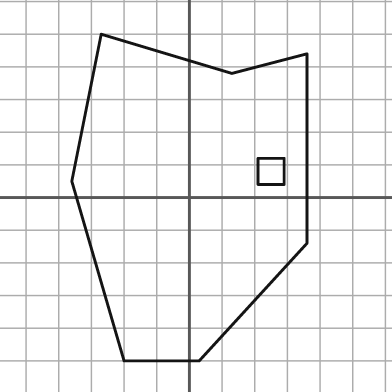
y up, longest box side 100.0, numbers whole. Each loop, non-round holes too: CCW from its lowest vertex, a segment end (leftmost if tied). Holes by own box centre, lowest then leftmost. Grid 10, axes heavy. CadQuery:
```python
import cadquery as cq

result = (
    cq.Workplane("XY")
    .moveTo(-20.0, -50.0)
    .lineTo(3.0, -50.0)
    .lineTo(36.0, -14.0)
    .lineTo(36.0, 44.0)
    .lineTo(13.0, 38.0)
    .lineTo(-27.0, 50.0)
    .lineTo(-36.0, 5.0)
    .close()
    .moveTo(21.0, 4.0)
    .lineTo(29.0, 4.0)
    .lineTo(29.0, 12.0)
    .lineTo(21.0, 12.0)
    .close()
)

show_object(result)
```